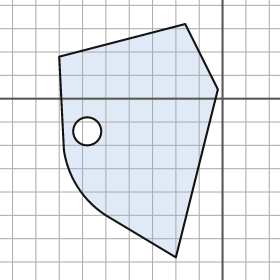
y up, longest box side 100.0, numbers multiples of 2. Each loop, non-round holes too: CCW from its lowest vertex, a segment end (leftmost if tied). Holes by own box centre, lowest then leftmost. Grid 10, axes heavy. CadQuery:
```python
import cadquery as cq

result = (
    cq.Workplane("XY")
    .moveTo(-20.0, -68.0)
    .lineTo(-2.0, 4.0)
    .lineTo(-16.0, 32.0)
    .lineTo(-70.0, 18.0)
    .lineTo(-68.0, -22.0)
    .threePointArc((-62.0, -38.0), (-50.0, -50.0))
    .close()
    .moveTo(-58.0, -14.0)
    .circle(6.0)
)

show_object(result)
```